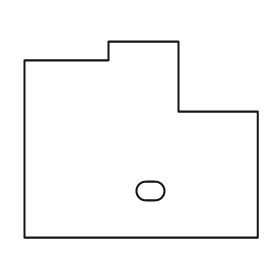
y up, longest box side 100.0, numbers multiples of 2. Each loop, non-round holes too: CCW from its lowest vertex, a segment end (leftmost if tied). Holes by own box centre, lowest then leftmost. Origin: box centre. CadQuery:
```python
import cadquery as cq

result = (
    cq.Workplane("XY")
    .moveTo(-50.0, -42.0)
    .lineTo(50.0, -42.0)
    .lineTo(50.0, 12.0)
    .lineTo(16.0, 12.0)
    .lineTo(16.0, 42.0)
    .lineTo(-14.0, 42.0)
    .lineTo(-14.0, 34.0)
    .lineTo(-50.0, 34.0)
    .close()
    .moveTo(2.0, -26.0)
    .lineTo(6.0, -26.0)
    .threePointArc((10.0, -22.0), (6.0, -18.0))
    .lineTo(2.0, -18.0)
    .threePointArc((-2.0, -22.0), (2.0, -26.0))
    .close()
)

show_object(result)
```